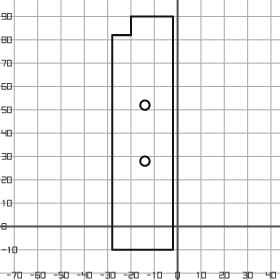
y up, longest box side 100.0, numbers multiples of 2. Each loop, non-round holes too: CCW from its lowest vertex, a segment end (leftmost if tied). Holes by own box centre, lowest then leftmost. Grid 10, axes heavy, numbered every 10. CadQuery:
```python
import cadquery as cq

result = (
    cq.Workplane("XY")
    .moveTo(-28.0, -10.0)
    .lineTo(-2.0, -10.0)
    .lineTo(-2.0, 90.0)
    .lineTo(-20.0, 90.0)
    .lineTo(-20.0, 82.0)
    .lineTo(-28.0, 82.0)
    .close()
    .moveTo(-14.0, 28.0)
    .circle(2.0)
    .moveTo(-14.0, 52.0)
    .circle(2.0)
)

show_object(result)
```